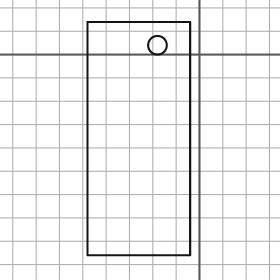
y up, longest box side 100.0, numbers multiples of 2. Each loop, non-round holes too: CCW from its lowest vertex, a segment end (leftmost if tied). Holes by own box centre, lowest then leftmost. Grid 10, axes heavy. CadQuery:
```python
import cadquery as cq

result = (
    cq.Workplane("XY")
    .moveTo(-48.0, -86.0)
    .lineTo(-4.0, -86.0)
    .lineTo(-4.0, 14.0)
    .lineTo(-48.0, 14.0)
    .close()
    .moveTo(-18.0, 4.0)
    .circle(4.0)
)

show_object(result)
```